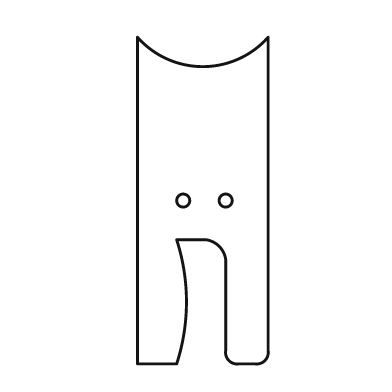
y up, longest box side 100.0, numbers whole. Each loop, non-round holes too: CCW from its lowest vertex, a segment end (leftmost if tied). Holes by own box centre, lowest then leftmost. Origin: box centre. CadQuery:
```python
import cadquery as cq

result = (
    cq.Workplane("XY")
    .moveTo(-20.0, -50.0)
    .lineTo(-8.0, -50.0)
    .threePointArc((-5.0, -31.0), (-8.0, -12.0))
    .lineTo(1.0, -12.0)
    .threePointArc((5.0, -14.0), (7.0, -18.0))
    .lineTo(7.0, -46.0)
    .threePointArc((8.0, -49.0), (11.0, -50.0))
    .lineTo(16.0, -50.0)
    .threePointArc((19.0, -49.0), (20.0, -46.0))
    .lineTo(20.0, 50.0)
    .threePointArc((0.0, 41.0), (-20.0, 50.0))
    .close()
    .moveTo(-6.0, 0.0)
    .circle(2.0)
    .moveTo(7.0, 0.0)
    .circle(2.0)
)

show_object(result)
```